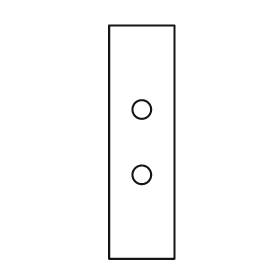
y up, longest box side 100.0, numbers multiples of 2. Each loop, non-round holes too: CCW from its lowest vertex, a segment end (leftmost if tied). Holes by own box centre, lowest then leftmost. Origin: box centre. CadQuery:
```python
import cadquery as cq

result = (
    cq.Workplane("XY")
    .moveTo(-14.0, -50.0)
    .lineTo(14.0, -50.0)
    .lineTo(14.0, 50.0)
    .lineTo(-14.0, 50.0)
    .close()
    .moveTo(0.0, -14.0)
    .circle(4.0)
    .moveTo(0.0, 14.0)
    .circle(4.0)
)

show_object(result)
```